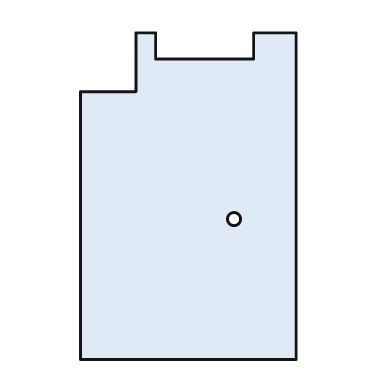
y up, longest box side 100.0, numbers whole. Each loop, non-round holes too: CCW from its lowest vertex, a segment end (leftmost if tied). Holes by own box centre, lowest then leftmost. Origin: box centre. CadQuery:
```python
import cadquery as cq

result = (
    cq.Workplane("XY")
    .moveTo(-33.0, -50.0)
    .lineTo(33.0, -50.0)
    .lineTo(33.0, 50.0)
    .lineTo(20.0, 50.0)
    .lineTo(20.0, 42.0)
    .lineTo(-10.0, 42.0)
    .lineTo(-10.0, 50.0)
    .lineTo(-16.0, 50.0)
    .lineTo(-16.0, 32.0)
    .lineTo(-33.0, 32.0)
    .close()
    .moveTo(14.0, -7.0)
    .circle(2.0)
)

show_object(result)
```